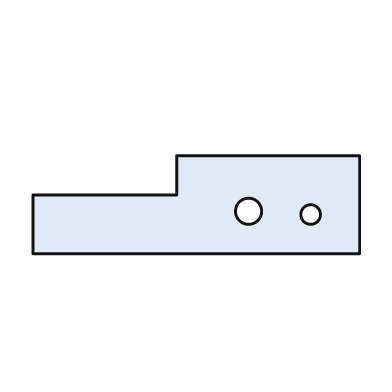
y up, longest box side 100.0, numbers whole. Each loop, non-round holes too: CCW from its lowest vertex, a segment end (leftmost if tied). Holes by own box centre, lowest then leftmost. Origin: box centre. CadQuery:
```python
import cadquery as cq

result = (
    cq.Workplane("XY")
    .moveTo(-50.0, -15.0)
    .lineTo(50.0, -15.0)
    .lineTo(50.0, 15.0)
    .lineTo(-6.0, 15.0)
    .lineTo(-6.0, 3.0)
    .lineTo(-50.0, 3.0)
    .close()
    .moveTo(35.0, -3.0)
    .circle(3.0)
    .moveTo(16.0, -2.0)
    .circle(4.0)
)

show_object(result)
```